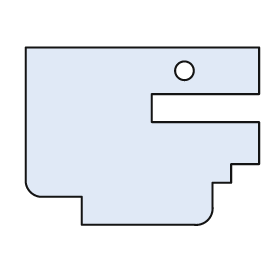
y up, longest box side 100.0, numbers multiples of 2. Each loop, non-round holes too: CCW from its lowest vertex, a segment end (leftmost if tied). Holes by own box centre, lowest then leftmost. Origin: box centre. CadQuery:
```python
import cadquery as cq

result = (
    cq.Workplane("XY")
    .moveTo(-26.0, -38.0)
    .lineTo(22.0, -38.0)
    .threePointArc((28.0, -36.0), (30.0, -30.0))
    .lineTo(30.0, -20.0)
    .lineTo(38.0, -20.0)
    .lineTo(38.0, -12.0)
    .lineTo(50.0, -12.0)
    .lineTo(50.0, 6.0)
    .lineTo(4.0, 6.0)
    .lineTo(4.0, 18.0)
    .lineTo(50.0, 18.0)
    .lineTo(50.0, 38.0)
    .lineTo(-50.0, 38.0)
    .lineTo(-50.0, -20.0)
    .threePointArc((-48.0, -24.0), (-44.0, -26.0))
    .lineTo(-26.0, -26.0)
    .close()
    .moveTo(18.0, 28.0)
    .circle(4.0)
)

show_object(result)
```